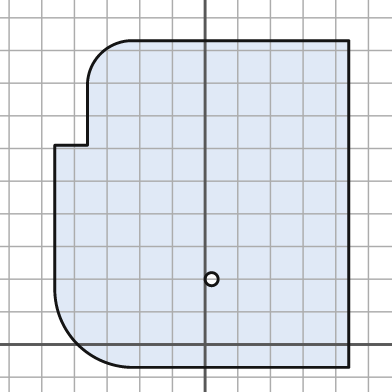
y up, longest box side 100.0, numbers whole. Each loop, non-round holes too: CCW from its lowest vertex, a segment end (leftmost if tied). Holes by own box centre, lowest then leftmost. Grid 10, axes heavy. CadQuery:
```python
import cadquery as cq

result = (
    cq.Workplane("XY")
    .moveTo(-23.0, -7.0)
    .lineTo(44.0, -7.0)
    .lineTo(44.0, 93.0)
    .lineTo(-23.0, 93.0)
    .threePointArc((-32.0, 89.0), (-36.0, 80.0))
    .lineTo(-36.0, 61.0)
    .lineTo(-46.0, 61.0)
    .lineTo(-46.0, 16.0)
    .threePointArc((-39.0, 0.0), (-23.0, -7.0))
    .close()
    .moveTo(2.0, 20.0)
    .circle(2.0)
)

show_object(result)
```